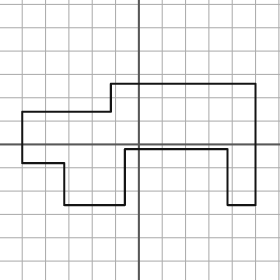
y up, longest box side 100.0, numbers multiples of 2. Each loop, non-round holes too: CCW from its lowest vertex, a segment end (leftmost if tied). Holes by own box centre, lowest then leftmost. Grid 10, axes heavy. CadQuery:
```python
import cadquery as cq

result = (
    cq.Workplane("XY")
    .moveTo(-32.0, -26.0)
    .lineTo(-6.0, -26.0)
    .lineTo(-6.0, -2.0)
    .lineTo(38.0, -2.0)
    .lineTo(38.0, -26.0)
    .lineTo(50.0, -26.0)
    .lineTo(50.0, 26.0)
    .lineTo(-12.0, 26.0)
    .lineTo(-12.0, 14.0)
    .lineTo(-50.0, 14.0)
    .lineTo(-50.0, -8.0)
    .lineTo(-32.0, -8.0)
    .close()
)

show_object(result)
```